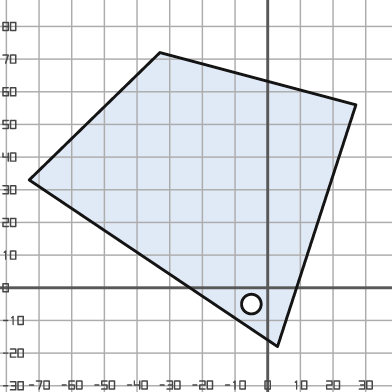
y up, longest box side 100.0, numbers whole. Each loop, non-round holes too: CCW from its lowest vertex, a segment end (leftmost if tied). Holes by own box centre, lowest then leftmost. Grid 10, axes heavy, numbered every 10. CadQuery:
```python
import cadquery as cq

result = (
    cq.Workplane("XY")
    .moveTo(3.0, -18.0)
    .lineTo(27.0, 56.0)
    .lineTo(-33.0, 72.0)
    .lineTo(-73.0, 33.0)
    .close()
    .moveTo(-5.0, -5.0)
    .circle(3.0)
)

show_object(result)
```